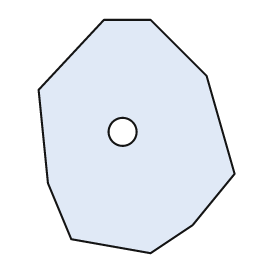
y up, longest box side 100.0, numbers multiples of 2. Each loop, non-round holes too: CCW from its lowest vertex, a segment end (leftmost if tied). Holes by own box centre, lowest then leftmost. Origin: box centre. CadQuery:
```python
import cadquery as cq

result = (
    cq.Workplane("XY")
    .moveTo(6.0, -50.0)
    .lineTo(24.0, -38.0)
    .lineTo(42.0, -16.0)
    .lineTo(30.0, 26.0)
    .lineTo(6.0, 50.0)
    .lineTo(-14.0, 50.0)
    .lineTo(-42.0, 20.0)
    .lineTo(-38.0, -20.0)
    .lineTo(-28.0, -44.0)
    .close()
    .moveTo(-6.0, 2.0)
    .circle(6.0)
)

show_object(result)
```